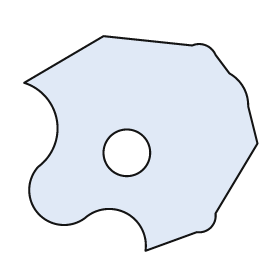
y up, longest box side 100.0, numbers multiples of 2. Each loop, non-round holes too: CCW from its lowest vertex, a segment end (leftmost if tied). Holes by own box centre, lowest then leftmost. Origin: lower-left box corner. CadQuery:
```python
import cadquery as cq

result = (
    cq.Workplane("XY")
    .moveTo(52.0, 0.0)
    .lineTo(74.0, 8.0)
    .threePointArc((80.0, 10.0), (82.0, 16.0))
    .lineTo(100.0, 46.0)
    .lineTo(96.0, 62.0)
    .threePointArc((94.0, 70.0), (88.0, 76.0))
    .lineTo(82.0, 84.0)
    .threePointArc((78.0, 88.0), (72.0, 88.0))
    .lineTo(34.0, 92.0)
    .lineTo(0.0, 72.0)
    .threePointArc((14.0, 56.0), (6.0, 36.0))
    .threePointArc((6.0, 16.0), (26.0, 14.0))
    .threePointArc((44.0, 16.0), (52.0, 0.0))
    .close()
    .moveTo(44.0, 42.0)
    .circle(10.0)
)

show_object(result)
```